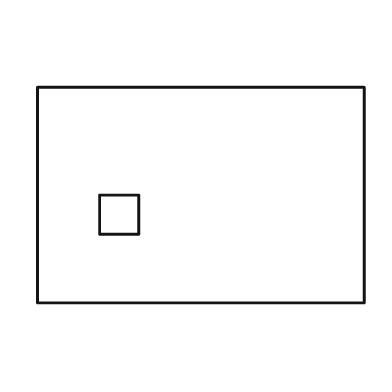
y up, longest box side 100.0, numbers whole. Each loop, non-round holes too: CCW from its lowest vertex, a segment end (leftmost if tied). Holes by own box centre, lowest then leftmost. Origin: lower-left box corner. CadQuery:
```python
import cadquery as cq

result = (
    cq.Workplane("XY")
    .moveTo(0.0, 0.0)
    .lineTo(100.0, 0.0)
    .lineTo(100.0, 66.0)
    .lineTo(0.0, 66.0)
    .close()
    .moveTo(19.0, 21.0)
    .lineTo(31.0, 21.0)
    .lineTo(31.0, 33.0)
    .lineTo(19.0, 33.0)
    .close()
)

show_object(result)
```